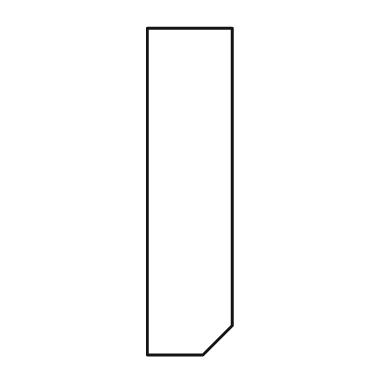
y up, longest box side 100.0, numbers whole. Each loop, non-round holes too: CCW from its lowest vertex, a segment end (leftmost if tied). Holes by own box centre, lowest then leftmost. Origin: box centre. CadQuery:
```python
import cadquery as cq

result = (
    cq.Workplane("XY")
    .moveTo(-13.0, -50.0)
    .lineTo(4.0, -50.0)
    .lineTo(13.0, -41.0)
    .lineTo(13.0, 50.0)
    .lineTo(-13.0, 50.0)
    .close()
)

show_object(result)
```